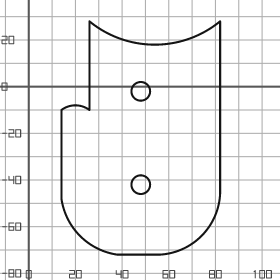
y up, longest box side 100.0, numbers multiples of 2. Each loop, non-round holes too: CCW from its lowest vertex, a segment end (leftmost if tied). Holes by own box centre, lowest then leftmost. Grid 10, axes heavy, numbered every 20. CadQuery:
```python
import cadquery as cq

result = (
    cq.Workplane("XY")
    .moveTo(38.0, -72.0)
    .lineTo(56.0, -72.0)
    .threePointArc((74.0, -64.0), (82.0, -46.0))
    .lineTo(82.0, 28.0)
    .threePointArc((54.0, 18.0), (26.0, 28.0))
    .lineTo(26.0, -10.0)
    .threePointArc((20.0, -8.0), (14.0, -10.0))
    .lineTo(14.0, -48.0)
    .threePointArc((22.0, -64.0), (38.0, -72.0))
    .close()
    .moveTo(48.0, -42.0)
    .circle(4.0)
    .moveTo(48.0, -2.0)
    .circle(4.0)
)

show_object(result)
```